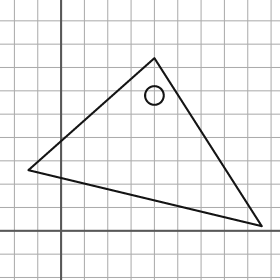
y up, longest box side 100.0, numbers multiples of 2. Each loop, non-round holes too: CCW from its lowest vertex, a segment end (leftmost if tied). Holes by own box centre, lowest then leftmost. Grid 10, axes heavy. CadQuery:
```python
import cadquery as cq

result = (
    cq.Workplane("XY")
    .moveTo(86.0, 2.0)
    .lineTo(40.0, 74.0)
    .lineTo(-14.0, 26.0)
    .close()
    .moveTo(40.0, 58.0)
    .circle(4.0)
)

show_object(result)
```